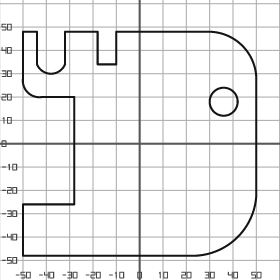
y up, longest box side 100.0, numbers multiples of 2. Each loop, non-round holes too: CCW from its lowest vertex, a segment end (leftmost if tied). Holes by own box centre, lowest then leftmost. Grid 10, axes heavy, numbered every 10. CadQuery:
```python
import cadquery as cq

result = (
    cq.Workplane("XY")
    .moveTo(-50.0, -48.0)
    .lineTo(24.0, -48.0)
    .threePointArc((42.0, -40.0), (50.0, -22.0))
    .lineTo(50.0, 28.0)
    .threePointArc((44.0, 42.0), (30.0, 48.0))
    .lineTo(-10.0, 48.0)
    .lineTo(-10.0, 34.0)
    .lineTo(-18.0, 34.0)
    .lineTo(-18.0, 48.0)
    .lineTo(-32.0, 48.0)
    .lineTo(-32.0, 34.0)
    .threePointArc((-38.0, 30.0), (-44.0, 34.0))
    .lineTo(-44.0, 48.0)
    .lineTo(-50.0, 48.0)
    .lineTo(-50.0, 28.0)
    .threePointArc((-48.0, 22.0), (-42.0, 20.0))
    .lineTo(-28.0, 20.0)
    .lineTo(-28.0, -26.0)
    .lineTo(-50.0, -26.0)
    .close()
    .moveTo(36.0, 18.0)
    .circle(6.0)
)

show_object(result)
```